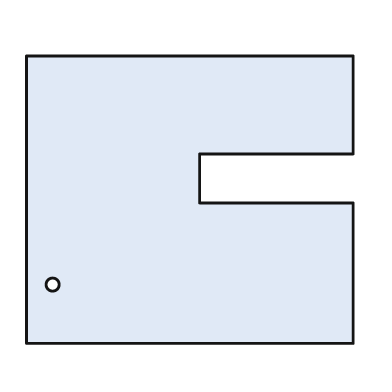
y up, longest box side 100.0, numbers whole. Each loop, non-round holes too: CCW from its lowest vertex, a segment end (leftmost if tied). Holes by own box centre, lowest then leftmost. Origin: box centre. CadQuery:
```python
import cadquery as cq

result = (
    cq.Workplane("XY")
    .moveTo(-50.0, -44.0)
    .lineTo(50.0, -44.0)
    .lineTo(50.0, -1.0)
    .lineTo(3.0, -1.0)
    .lineTo(3.0, 14.0)
    .lineTo(50.0, 14.0)
    .lineTo(50.0, 44.0)
    .lineTo(-50.0, 44.0)
    .close()
    .moveTo(-42.0, -26.0)
    .circle(2.0)
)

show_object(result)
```